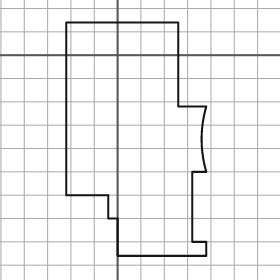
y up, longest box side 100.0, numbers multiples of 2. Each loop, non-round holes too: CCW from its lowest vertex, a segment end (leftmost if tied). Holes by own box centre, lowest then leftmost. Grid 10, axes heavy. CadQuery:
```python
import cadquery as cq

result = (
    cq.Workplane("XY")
    .moveTo(0.0, -86.0)
    .lineTo(38.0, -86.0)
    .lineTo(38.0, -80.0)
    .lineTo(32.0, -80.0)
    .lineTo(32.0, -50.0)
    .lineTo(38.0, -50.0)
    .threePointArc((36.0, -36.0), (38.0, -22.0))
    .lineTo(26.0, -22.0)
    .lineTo(26.0, 14.0)
    .lineTo(-22.0, 14.0)
    .lineTo(-22.0, -60.0)
    .lineTo(-4.0, -60.0)
    .lineTo(-4.0, -70.0)
    .lineTo(0.0, -70.0)
    .close()
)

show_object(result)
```